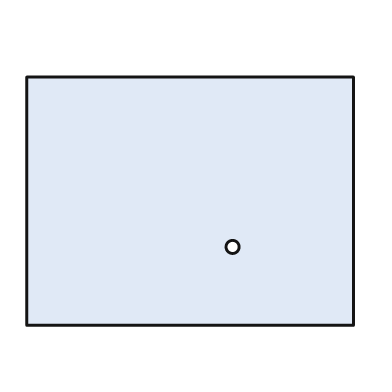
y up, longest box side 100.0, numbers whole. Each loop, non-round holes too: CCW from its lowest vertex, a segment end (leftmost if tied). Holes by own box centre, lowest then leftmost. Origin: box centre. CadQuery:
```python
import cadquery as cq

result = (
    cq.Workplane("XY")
    .moveTo(-50.0, -38.0)
    .lineTo(50.0, -38.0)
    .lineTo(50.0, 38.0)
    .lineTo(-50.0, 38.0)
    .close()
    .moveTo(13.0, -14.0)
    .circle(2.0)
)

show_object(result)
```